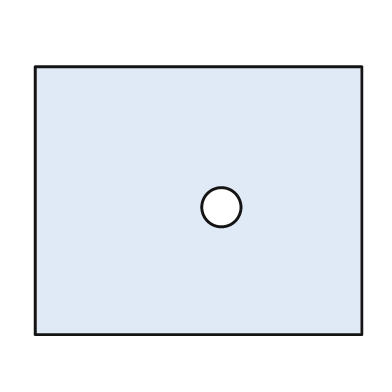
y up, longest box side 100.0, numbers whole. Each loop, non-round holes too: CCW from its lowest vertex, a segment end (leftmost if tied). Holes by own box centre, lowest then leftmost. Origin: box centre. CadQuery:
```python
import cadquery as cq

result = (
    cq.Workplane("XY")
    .moveTo(-50.0, -41.0)
    .lineTo(50.0, -41.0)
    .lineTo(50.0, 41.0)
    .lineTo(-50.0, 41.0)
    .close()
    .moveTo(7.0, -2.0)
    .circle(6.0)
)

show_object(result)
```